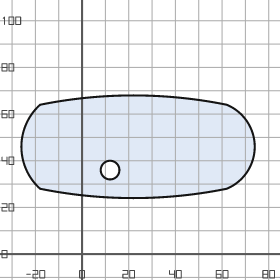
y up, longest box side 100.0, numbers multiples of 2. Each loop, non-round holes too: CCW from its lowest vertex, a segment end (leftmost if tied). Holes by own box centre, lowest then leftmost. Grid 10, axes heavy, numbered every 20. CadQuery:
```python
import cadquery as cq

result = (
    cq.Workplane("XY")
    .moveTo(-18.0, 28.0)
    .threePointArc((22.0, 24.0), (62.0, 28.0))
    .threePointArc((74.0, 46.0), (62.0, 64.0))
    .threePointArc((22.0, 68.0), (-18.0, 64.0))
    .threePointArc((-26.0, 46.0), (-18.0, 28.0))
    .close()
    .moveTo(12.0, 36.0)
    .circle(4.0)
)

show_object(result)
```